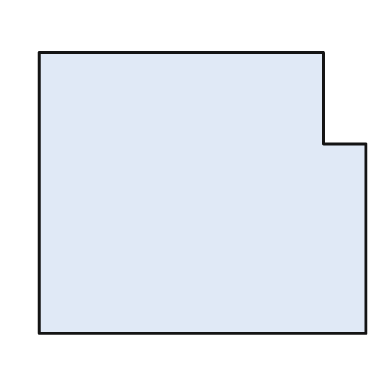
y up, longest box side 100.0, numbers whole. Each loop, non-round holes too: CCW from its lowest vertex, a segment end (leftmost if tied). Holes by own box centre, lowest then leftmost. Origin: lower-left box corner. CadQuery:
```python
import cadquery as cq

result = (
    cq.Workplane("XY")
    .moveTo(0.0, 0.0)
    .lineTo(100.0, 0.0)
    .lineTo(100.0, 58.0)
    .lineTo(87.0, 58.0)
    .lineTo(87.0, 86.0)
    .lineTo(0.0, 86.0)
    .close()
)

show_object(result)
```